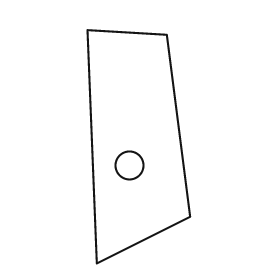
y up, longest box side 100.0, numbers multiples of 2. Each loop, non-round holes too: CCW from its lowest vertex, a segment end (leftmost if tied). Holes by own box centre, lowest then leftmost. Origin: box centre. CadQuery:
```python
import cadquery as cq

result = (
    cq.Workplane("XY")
    .moveTo(-18.0, -50.0)
    .lineTo(22.0, -30.0)
    .lineTo(12.0, 48.0)
    .lineTo(-22.0, 50.0)
    .close()
    .moveTo(-4.0, -8.0)
    .circle(6.0)
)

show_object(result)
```